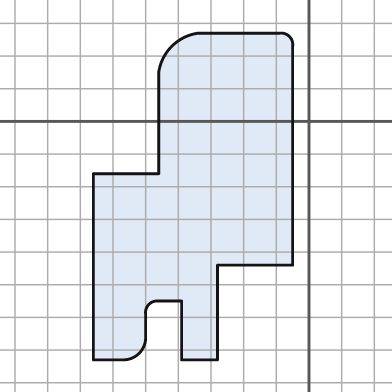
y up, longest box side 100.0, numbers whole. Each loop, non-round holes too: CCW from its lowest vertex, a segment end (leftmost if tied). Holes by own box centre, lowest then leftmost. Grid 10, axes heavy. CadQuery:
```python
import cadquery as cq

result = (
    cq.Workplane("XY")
    .moveTo(-66.0, -73.0)
    .lineTo(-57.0, -73.0)
    .threePointArc((-52.0, -71.0), (-50.0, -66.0))
    .lineTo(-50.0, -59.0)
    .threePointArc((-49.0, -56.0), (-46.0, -55.0))
    .lineTo(-39.0, -55.0)
    .lineTo(-39.0, -73.0)
    .lineTo(-28.0, -73.0)
    .lineTo(-28.0, -44.0)
    .lineTo(-5.0, -44.0)
    .lineTo(-5.0, 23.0)
    .threePointArc((-6.0, 26.0), (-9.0, 27.0))
    .lineTo(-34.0, 27.0)
    .threePointArc((-42.0, 23.0), (-46.0, 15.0))
    .lineTo(-46.0, -16.0)
    .lineTo(-66.0, -16.0)
    .close()
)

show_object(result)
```